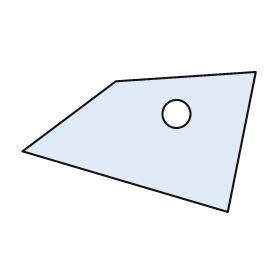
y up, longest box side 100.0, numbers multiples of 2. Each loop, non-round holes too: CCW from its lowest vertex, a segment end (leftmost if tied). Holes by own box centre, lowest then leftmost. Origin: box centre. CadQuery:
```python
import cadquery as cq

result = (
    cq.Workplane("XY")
    .moveTo(38.0, -30.0)
    .lineTo(50.0, 30.0)
    .lineTo(-10.0, 26.0)
    .lineTo(-50.0, -4.0)
    .close()
    .moveTo(16.0, 12.0)
    .circle(6.0)
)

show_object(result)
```